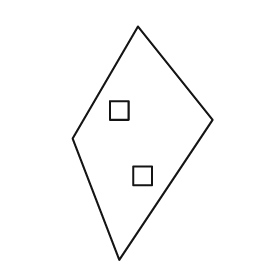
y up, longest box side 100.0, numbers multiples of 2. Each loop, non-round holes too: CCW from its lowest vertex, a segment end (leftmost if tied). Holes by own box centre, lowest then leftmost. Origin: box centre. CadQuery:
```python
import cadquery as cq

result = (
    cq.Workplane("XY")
    .moveTo(-10.0, -50.0)
    .lineTo(30.0, 10.0)
    .lineTo(-2.0, 50.0)
    .lineTo(-30.0, 2.0)
    .close()
    .moveTo(-4.0, -18.0)
    .lineTo(4.0, -18.0)
    .lineTo(4.0, -10.0)
    .lineTo(-4.0, -10.0)
    .close()
    .moveTo(-14.0, 10.0)
    .lineTo(-6.0, 10.0)
    .lineTo(-6.0, 18.0)
    .lineTo(-14.0, 18.0)
    .close()
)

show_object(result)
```